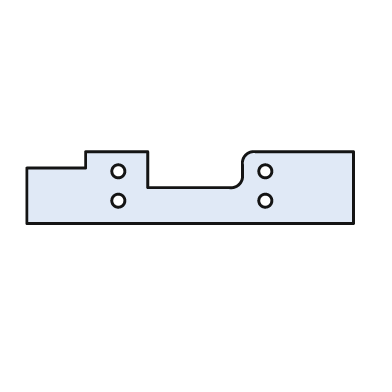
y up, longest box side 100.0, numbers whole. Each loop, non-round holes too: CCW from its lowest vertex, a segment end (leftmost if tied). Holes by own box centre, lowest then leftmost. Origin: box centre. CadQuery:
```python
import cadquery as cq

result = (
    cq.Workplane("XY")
    .moveTo(-50.0, -11.0)
    .lineTo(50.0, -11.0)
    .lineTo(50.0, 11.0)
    .lineTo(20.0, 11.0)
    .threePointArc((17.0, 10.0), (16.0, 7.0))
    .lineTo(16.0, 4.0)
    .threePointArc((15.0, 1.0), (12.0, 0.0))
    .lineTo(-13.0, 0.0)
    .lineTo(-13.0, 11.0)
    .lineTo(-32.0, 11.0)
    .lineTo(-32.0, 6.0)
    .lineTo(-50.0, 6.0)
    .close()
    .moveTo(-22.0, -4.0)
    .circle(2.0)
    .moveTo(23.0, -4.0)
    .circle(2.0)
    .moveTo(-22.0, 5.0)
    .circle(2.0)
    .moveTo(23.0, 5.0)
    .circle(2.0)
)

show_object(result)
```